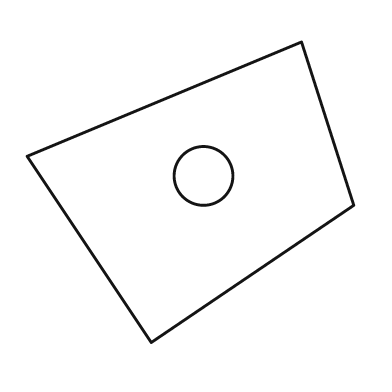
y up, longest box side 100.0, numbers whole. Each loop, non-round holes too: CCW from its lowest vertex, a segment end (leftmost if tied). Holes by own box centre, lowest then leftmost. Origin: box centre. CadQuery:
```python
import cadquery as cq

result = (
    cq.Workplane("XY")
    .moveTo(-12.0, -46.0)
    .lineTo(50.0, -4.0)
    .lineTo(34.0, 46.0)
    .lineTo(-50.0, 11.0)
    .close()
    .moveTo(4.0, 5.0)
    .circle(9.0)
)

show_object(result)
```